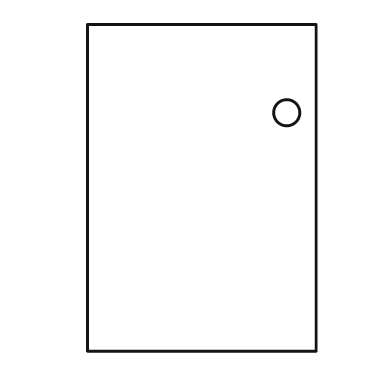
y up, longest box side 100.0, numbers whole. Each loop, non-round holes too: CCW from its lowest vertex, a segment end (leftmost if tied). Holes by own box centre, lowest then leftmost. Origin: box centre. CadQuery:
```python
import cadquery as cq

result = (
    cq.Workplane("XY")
    .moveTo(-35.0, -50.0)
    .lineTo(35.0, -50.0)
    .lineTo(35.0, 50.0)
    .lineTo(-35.0, 50.0)
    .close()
    .moveTo(26.0, 23.0)
    .circle(4.0)
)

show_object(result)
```